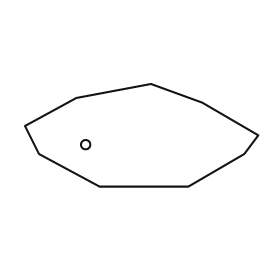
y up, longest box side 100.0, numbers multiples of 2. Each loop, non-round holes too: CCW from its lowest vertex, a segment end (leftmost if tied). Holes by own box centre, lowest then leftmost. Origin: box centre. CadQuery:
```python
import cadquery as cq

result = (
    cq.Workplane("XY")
    .moveTo(-18.0, -22.0)
    .lineTo(20.0, -22.0)
    .lineTo(44.0, -8.0)
    .lineTo(50.0, 0.0)
    .lineTo(26.0, 14.0)
    .lineTo(4.0, 22.0)
    .lineTo(-28.0, 16.0)
    .lineTo(-50.0, 4.0)
    .lineTo(-44.0, -8.0)
    .close()
    .moveTo(-24.0, -4.0)
    .circle(2.0)
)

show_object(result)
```